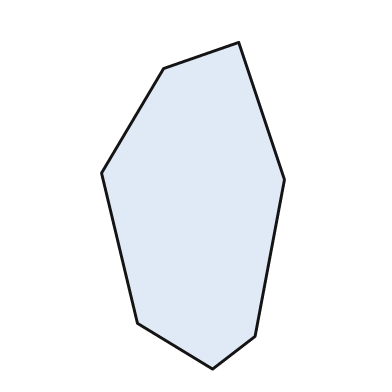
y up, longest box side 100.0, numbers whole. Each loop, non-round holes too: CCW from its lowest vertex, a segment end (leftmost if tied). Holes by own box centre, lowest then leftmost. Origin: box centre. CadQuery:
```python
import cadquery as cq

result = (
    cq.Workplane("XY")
    .moveTo(6.0, -50.0)
    .lineTo(19.0, -40.0)
    .lineTo(28.0, 8.0)
    .lineTo(14.0, 50.0)
    .lineTo(-9.0, 42.0)
    .lineTo(-28.0, 10.0)
    .lineTo(-17.0, -36.0)
    .close()
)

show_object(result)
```